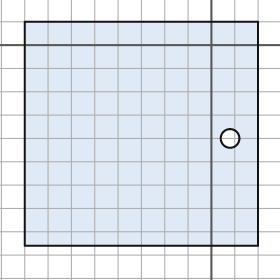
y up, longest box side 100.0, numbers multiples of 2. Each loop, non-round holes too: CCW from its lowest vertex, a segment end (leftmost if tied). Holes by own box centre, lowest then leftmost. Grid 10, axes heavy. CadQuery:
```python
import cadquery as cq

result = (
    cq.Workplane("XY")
    .moveTo(-80.0, -86.0)
    .lineTo(20.0, -86.0)
    .lineTo(20.0, 10.0)
    .lineTo(-80.0, 10.0)
    .close()
    .moveTo(8.0, -40.0)
    .circle(4.0)
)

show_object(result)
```